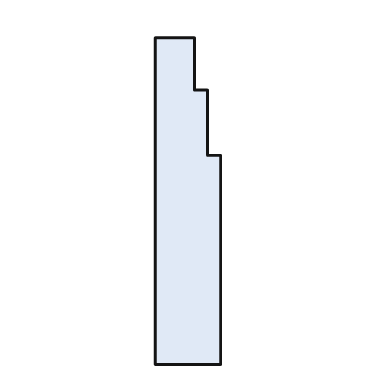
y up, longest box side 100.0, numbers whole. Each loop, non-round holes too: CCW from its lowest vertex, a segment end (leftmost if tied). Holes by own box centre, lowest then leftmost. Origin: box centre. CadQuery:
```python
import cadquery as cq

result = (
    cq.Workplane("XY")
    .moveTo(-10.0, -50.0)
    .lineTo(10.0, -50.0)
    .lineTo(10.0, 14.0)
    .lineTo(6.0, 14.0)
    .lineTo(6.0, 34.0)
    .lineTo(2.0, 34.0)
    .lineTo(2.0, 50.0)
    .lineTo(-10.0, 50.0)
    .close()
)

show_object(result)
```